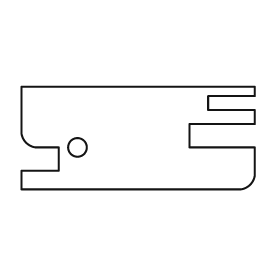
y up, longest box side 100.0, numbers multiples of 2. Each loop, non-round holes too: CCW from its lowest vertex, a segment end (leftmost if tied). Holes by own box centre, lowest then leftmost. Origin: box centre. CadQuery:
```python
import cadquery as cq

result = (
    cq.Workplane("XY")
    .moveTo(-50.0, -22.0)
    .lineTo(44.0, -22.0)
    .threePointArc((48.0, -20.0), (50.0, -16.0))
    .lineTo(50.0, -4.0)
    .lineTo(22.0, -4.0)
    .lineTo(22.0, 6.0)
    .lineTo(50.0, 6.0)
    .lineTo(50.0, 12.0)
    .lineTo(30.0, 12.0)
    .lineTo(30.0, 18.0)
    .lineTo(50.0, 18.0)
    .lineTo(50.0, 22.0)
    .lineTo(-50.0, 22.0)
    .lineTo(-50.0, 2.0)
    .threePointArc((-48.0, -2.0), (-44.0, -4.0))
    .lineTo(-34.0, -4.0)
    .lineTo(-34.0, -14.0)
    .lineTo(-50.0, -14.0)
    .close()
    .moveTo(-26.0, -4.0)
    .circle(4.0)
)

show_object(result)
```